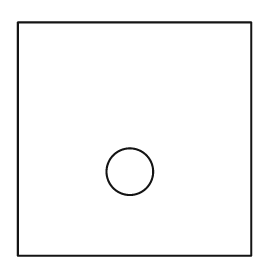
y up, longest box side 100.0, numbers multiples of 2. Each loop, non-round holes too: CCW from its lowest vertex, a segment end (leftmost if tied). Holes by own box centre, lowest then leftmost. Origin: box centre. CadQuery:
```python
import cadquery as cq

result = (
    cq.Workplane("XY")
    .moveTo(-50.0, -50.0)
    .lineTo(50.0, -50.0)
    .lineTo(50.0, 50.0)
    .lineTo(-50.0, 50.0)
    .close()
    .moveTo(-2.0, -14.0)
    .circle(10.0)
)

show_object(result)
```